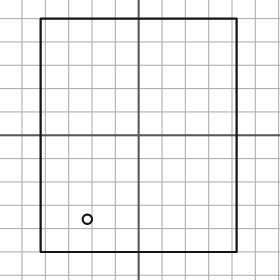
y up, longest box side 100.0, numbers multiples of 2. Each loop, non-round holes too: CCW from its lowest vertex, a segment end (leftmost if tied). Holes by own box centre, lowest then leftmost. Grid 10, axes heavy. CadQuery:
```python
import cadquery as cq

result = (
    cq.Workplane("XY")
    .moveTo(-42.0, -50.0)
    .lineTo(42.0, -50.0)
    .lineTo(42.0, 50.0)
    .lineTo(-42.0, 50.0)
    .close()
    .moveTo(-22.0, -36.0)
    .circle(2.0)
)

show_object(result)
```